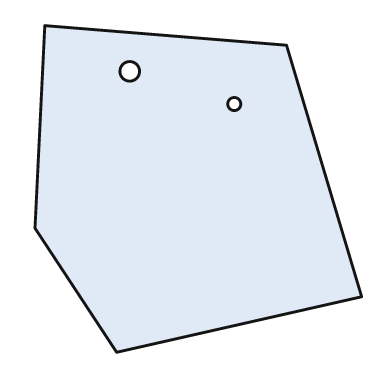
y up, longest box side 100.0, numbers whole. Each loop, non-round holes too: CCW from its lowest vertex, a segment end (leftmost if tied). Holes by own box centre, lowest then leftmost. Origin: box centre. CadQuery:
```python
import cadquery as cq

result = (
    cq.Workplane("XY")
    .moveTo(-25.0, -50.0)
    .lineTo(50.0, -33.0)
    .lineTo(27.0, 44.0)
    .lineTo(-47.0, 50.0)
    .lineTo(-50.0, -12.0)
    .close()
    .moveTo(11.0, 26.0)
    .circle(2.0)
    .moveTo(-21.0, 36.0)
    .circle(3.0)
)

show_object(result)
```